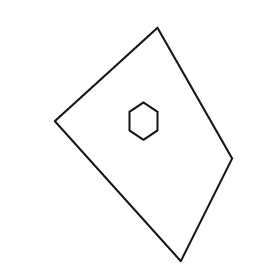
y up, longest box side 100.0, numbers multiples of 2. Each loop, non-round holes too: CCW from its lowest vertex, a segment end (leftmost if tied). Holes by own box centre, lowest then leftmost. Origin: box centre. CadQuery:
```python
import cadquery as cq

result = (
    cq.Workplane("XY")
    .moveTo(16.0, -50.0)
    .lineTo(38.0, -6.0)
    .lineTo(6.0, 50.0)
    .lineTo(-38.0, 10.0)
    .close()
    .moveTo(0.0, 2.0)
    .lineTo(6.0, 6.0)
    .lineTo(6.0, 14.0)
    .lineTo(0.0, 18.0)
    .lineTo(-6.0, 14.0)
    .lineTo(-6.0, 6.0)
    .close()
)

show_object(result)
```